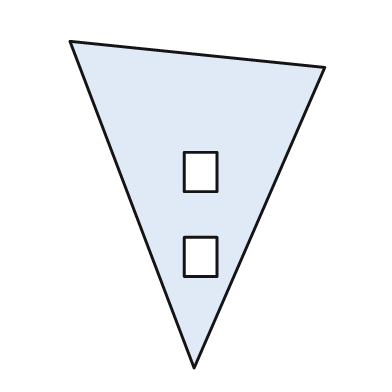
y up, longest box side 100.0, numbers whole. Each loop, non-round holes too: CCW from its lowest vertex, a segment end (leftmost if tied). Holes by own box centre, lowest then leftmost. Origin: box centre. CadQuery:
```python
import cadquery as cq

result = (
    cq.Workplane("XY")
    .moveTo(-1.0, -50.0)
    .lineTo(39.0, 42.0)
    .lineTo(-39.0, 50.0)
    .close()
    .moveTo(-4.0, -22.0)
    .lineTo(6.0, -22.0)
    .lineTo(6.0, -10.0)
    .lineTo(-4.0, -10.0)
    .close()
    .moveTo(-4.0, 4.0)
    .lineTo(6.0, 4.0)
    .lineTo(6.0, 16.0)
    .lineTo(-4.0, 16.0)
    .close()
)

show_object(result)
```